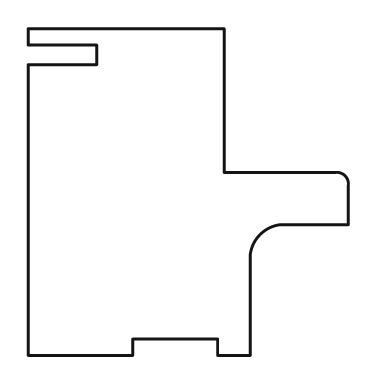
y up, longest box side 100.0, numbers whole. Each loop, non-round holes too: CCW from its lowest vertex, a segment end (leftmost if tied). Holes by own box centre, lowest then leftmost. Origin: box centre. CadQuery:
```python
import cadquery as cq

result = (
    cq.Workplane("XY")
    .moveTo(-49.0, -50.0)
    .lineTo(-17.0, -50.0)
    .lineTo(-17.0, -45.0)
    .lineTo(9.0, -45.0)
    .lineTo(9.0, -50.0)
    .lineTo(19.0, -50.0)
    .lineTo(19.0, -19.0)
    .threePointArc((22.0, -13.0), (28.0, -10.0))
    .lineTo(49.0, -10.0)
    .lineTo(49.0, 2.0)
    .threePointArc((48.0, 5.0), (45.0, 6.0))
    .lineTo(11.0, 6.0)
    .lineTo(11.0, 50.0)
    .lineTo(-49.0, 50.0)
    .lineTo(-49.0, 45.0)
    .lineTo(-28.0, 45.0)
    .lineTo(-28.0, 39.0)
    .lineTo(-49.0, 39.0)
    .close()
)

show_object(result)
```